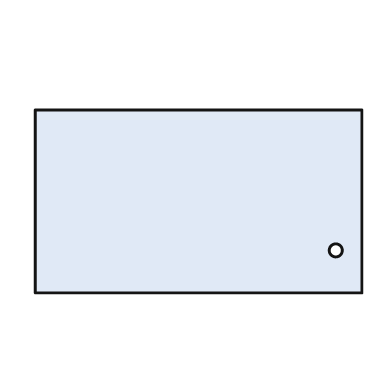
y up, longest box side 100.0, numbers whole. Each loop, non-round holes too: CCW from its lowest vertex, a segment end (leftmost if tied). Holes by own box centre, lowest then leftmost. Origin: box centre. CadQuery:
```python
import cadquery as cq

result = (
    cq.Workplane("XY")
    .moveTo(-50.0, -28.0)
    .lineTo(50.0, -28.0)
    .lineTo(50.0, 28.0)
    .lineTo(-50.0, 28.0)
    .close()
    .moveTo(42.0, -15.0)
    .circle(2.0)
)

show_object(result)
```